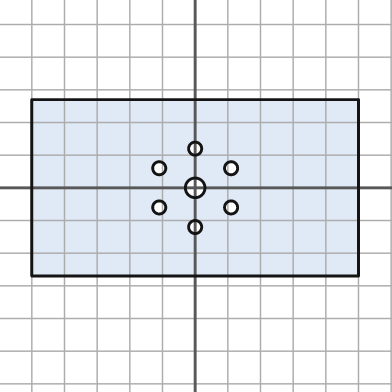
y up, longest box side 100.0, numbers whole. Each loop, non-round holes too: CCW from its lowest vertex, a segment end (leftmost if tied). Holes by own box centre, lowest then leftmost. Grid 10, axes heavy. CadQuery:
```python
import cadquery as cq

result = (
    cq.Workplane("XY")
    .moveTo(-50.0, -27.0)
    .lineTo(50.0, -27.0)
    .lineTo(50.0, 27.0)
    .lineTo(-50.0, 27.0)
    .close()
    .moveTo(0.0, -12.0)
    .circle(2.0)
    .moveTo(-11.0, -6.0)
    .circle(2.0)
    .moveTo(11.0, -6.0)
    .circle(2.0)
    .moveTo(0.0, 0.0)
    .circle(3.0)
    .moveTo(-11.0, 6.0)
    .circle(2.0)
    .moveTo(11.0, 6.0)
    .circle(2.0)
    .moveTo(0.0, 12.0)
    .circle(2.0)
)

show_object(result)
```